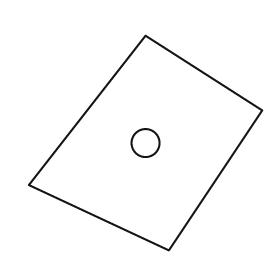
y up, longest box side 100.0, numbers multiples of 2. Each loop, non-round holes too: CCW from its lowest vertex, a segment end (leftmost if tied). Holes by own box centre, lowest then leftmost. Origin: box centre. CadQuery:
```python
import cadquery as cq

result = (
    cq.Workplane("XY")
    .moveTo(10.0, -46.0)
    .lineTo(50.0, 14.0)
    .lineTo(0.0, 46.0)
    .lineTo(-50.0, -18.0)
    .close()
    .moveTo(0.0, 0.0)
    .circle(6.0)
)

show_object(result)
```